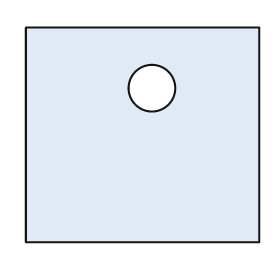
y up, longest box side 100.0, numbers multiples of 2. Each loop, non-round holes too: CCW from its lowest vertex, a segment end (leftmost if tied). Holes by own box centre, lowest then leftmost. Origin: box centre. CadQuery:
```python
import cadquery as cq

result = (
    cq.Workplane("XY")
    .moveTo(-50.0, -46.0)
    .lineTo(50.0, -46.0)
    .lineTo(50.0, 46.0)
    .lineTo(-50.0, 46.0)
    .close()
    .moveTo(4.0, 20.0)
    .circle(10.0)
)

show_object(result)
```